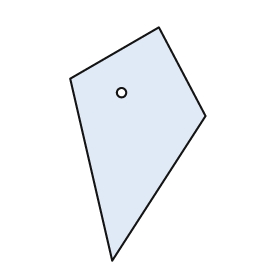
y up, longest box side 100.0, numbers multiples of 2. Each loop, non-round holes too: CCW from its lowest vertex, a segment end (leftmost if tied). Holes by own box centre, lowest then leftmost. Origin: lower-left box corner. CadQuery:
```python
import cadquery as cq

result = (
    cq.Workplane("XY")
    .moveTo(18.0, 0.0)
    .lineTo(58.0, 62.0)
    .lineTo(38.0, 100.0)
    .lineTo(0.0, 78.0)
    .close()
    .moveTo(22.0, 72.0)
    .circle(2.0)
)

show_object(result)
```